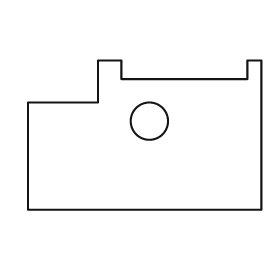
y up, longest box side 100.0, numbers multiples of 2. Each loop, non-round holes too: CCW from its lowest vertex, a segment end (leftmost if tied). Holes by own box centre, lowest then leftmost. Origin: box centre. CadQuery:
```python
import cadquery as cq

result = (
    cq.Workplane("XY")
    .moveTo(-50.0, -32.0)
    .lineTo(50.0, -32.0)
    .lineTo(50.0, 32.0)
    .lineTo(44.0, 32.0)
    .lineTo(44.0, 24.0)
    .lineTo(-10.0, 24.0)
    .lineTo(-10.0, 32.0)
    .lineTo(-20.0, 32.0)
    .lineTo(-20.0, 14.0)
    .lineTo(-50.0, 14.0)
    .close()
    .moveTo(2.0, 6.0)
    .circle(8.0)
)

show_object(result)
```